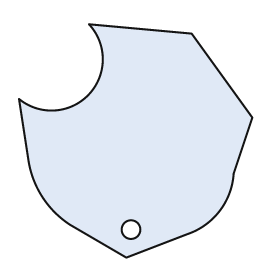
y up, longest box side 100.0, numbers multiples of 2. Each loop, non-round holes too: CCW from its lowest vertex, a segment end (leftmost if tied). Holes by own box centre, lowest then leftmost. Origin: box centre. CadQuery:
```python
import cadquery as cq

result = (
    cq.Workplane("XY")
    .moveTo(-4.0, -50.0)
    .lineTo(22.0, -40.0)
    .threePointArc((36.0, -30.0), (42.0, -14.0))
    .lineTo(50.0, 10.0)
    .lineTo(24.0, 46.0)
    .lineTo(-20.0, 50.0)
    .threePointArc((-20.0, 20.0), (-50.0, 18.0))
    .lineTo(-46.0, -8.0)
    .threePointArc((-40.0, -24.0), (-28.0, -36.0))
    .close()
    .moveTo(-2.0, -38.0)
    .circle(4.0)
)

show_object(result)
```